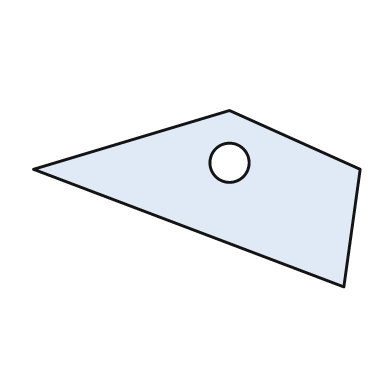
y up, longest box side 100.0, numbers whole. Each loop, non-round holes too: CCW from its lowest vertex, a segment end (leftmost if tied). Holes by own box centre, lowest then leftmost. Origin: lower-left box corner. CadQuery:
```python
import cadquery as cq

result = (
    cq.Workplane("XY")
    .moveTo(95.0, 0.0)
    .lineTo(100.0, 36.0)
    .lineTo(60.0, 54.0)
    .lineTo(0.0, 36.0)
    .close()
    .moveTo(60.0, 38.0)
    .circle(6.0)
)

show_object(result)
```